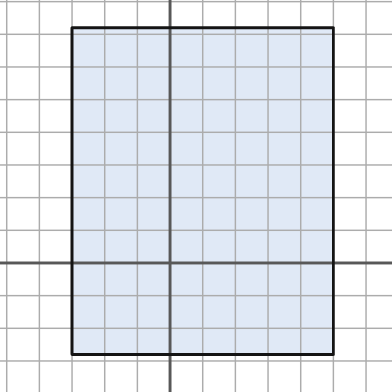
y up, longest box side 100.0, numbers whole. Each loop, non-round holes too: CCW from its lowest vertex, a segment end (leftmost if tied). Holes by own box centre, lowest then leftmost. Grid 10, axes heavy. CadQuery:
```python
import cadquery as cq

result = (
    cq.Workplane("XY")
    .moveTo(-30.0, -28.0)
    .lineTo(50.0, -28.0)
    .lineTo(50.0, 72.0)
    .lineTo(-30.0, 72.0)
    .close()
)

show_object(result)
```